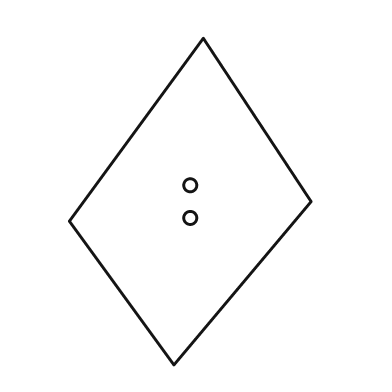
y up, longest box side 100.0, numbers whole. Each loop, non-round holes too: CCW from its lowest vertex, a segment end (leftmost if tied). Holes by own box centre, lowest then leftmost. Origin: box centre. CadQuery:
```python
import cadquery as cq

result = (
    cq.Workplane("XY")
    .moveTo(-5.0, -50.0)
    .lineTo(37.0, 0.0)
    .lineTo(4.0, 50.0)
    .lineTo(-37.0, -6.0)
    .close()
    .moveTo(0.0, -5.0)
    .circle(2.0)
    .moveTo(0.0, 5.0)
    .circle(2.0)
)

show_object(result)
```